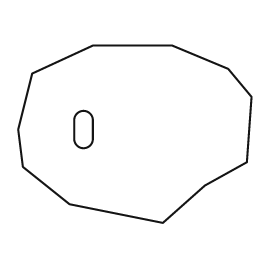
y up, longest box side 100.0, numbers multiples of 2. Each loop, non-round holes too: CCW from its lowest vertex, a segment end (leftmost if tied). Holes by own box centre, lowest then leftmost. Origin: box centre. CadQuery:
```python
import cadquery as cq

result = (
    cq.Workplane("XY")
    .moveTo(12.0, -38.0)
    .lineTo(30.0, -22.0)
    .lineTo(48.0, -12.0)
    .lineTo(50.0, 16.0)
    .lineTo(40.0, 28.0)
    .lineTo(16.0, 38.0)
    .lineTo(-18.0, 38.0)
    .lineTo(-44.0, 26.0)
    .lineTo(-50.0, 2.0)
    .lineTo(-48.0, -14.0)
    .lineTo(-28.0, -30.0)
    .close()
    .moveTo(-26.0, -2.0)
    .threePointArc((-22.0, -6.0), (-18.0, -2.0))
    .lineTo(-18.0, 6.0)
    .threePointArc((-22.0, 10.0), (-26.0, 6.0))
    .close()
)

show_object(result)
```